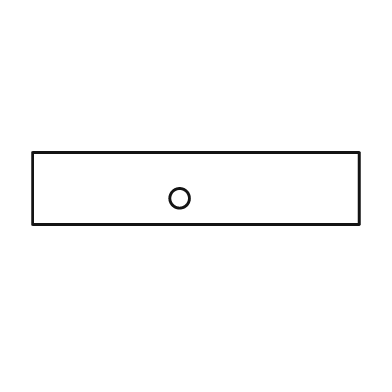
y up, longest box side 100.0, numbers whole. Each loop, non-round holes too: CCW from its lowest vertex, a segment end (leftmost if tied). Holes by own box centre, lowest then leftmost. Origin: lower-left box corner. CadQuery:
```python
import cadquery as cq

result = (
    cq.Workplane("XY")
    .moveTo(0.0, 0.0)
    .lineTo(100.0, 0.0)
    .lineTo(100.0, 22.0)
    .lineTo(0.0, 22.0)
    .close()
    .moveTo(45.0, 8.0)
    .circle(3.0)
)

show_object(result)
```